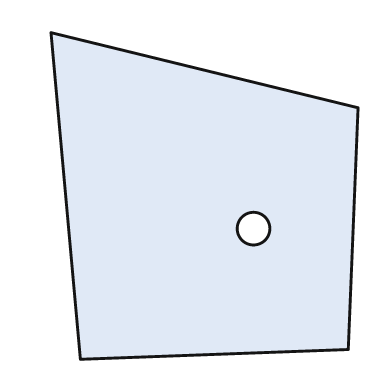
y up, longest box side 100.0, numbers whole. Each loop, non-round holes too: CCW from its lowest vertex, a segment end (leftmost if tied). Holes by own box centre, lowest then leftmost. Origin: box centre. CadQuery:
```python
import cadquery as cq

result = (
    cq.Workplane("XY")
    .moveTo(-38.0, -50.0)
    .lineTo(44.0, -47.0)
    .lineTo(47.0, 27.0)
    .lineTo(-47.0, 50.0)
    .close()
    .moveTo(15.0, -10.0)
    .circle(5.0)
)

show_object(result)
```